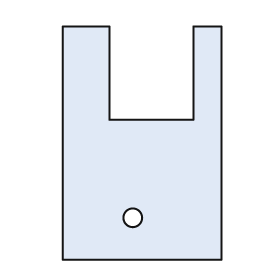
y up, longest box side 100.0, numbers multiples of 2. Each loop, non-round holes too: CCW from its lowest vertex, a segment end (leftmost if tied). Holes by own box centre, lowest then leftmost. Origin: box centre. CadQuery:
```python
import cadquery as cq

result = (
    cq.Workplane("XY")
    .moveTo(-34.0, -50.0)
    .lineTo(34.0, -50.0)
    .lineTo(34.0, 50.0)
    .lineTo(22.0, 50.0)
    .lineTo(22.0, 10.0)
    .lineTo(-14.0, 10.0)
    .lineTo(-14.0, 50.0)
    .lineTo(-34.0, 50.0)
    .close()
    .moveTo(-4.0, -32.0)
    .circle(4.0)
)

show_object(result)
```